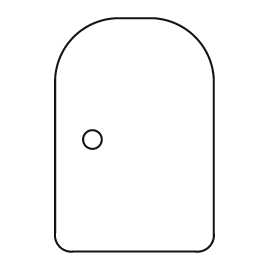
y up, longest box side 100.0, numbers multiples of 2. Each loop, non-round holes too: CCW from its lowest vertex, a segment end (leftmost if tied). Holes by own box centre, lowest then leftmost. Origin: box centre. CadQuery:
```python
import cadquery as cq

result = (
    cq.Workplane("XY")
    .moveTo(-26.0, -50.0)
    .lineTo(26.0, -50.0)
    .threePointArc((32.0, -48.0), (34.0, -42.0))
    .lineTo(34.0, 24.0)
    .threePointArc((26.0, 42.0), (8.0, 50.0))
    .lineTo(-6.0, 50.0)
    .threePointArc((-26.0, 42.0), (-34.0, 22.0))
    .lineTo(-34.0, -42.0)
    .threePointArc((-32.0, -48.0), (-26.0, -50.0))
    .close()
    .moveTo(-18.0, -2.0)
    .circle(4.0)
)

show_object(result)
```